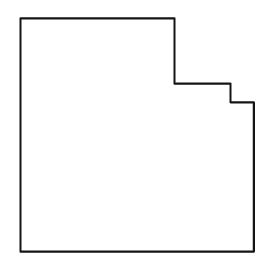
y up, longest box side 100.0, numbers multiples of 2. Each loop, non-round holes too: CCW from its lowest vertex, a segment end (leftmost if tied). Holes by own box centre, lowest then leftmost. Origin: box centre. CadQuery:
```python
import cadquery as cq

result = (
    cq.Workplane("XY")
    .moveTo(-50.0, -50.0)
    .lineTo(50.0, -50.0)
    .lineTo(50.0, 14.0)
    .lineTo(40.0, 14.0)
    .lineTo(40.0, 22.0)
    .lineTo(16.0, 22.0)
    .lineTo(16.0, 50.0)
    .lineTo(-50.0, 50.0)
    .close()
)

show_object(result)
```